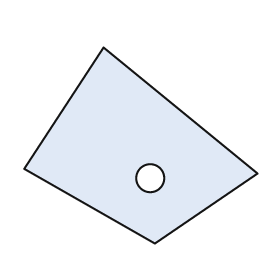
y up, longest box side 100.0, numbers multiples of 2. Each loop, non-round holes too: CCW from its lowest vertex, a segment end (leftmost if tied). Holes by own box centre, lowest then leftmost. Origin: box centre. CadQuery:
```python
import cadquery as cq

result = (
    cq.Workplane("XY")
    .moveTo(6.0, -42.0)
    .lineTo(50.0, -12.0)
    .lineTo(-16.0, 42.0)
    .lineTo(-50.0, -10.0)
    .close()
    .moveTo(4.0, -14.0)
    .circle(6.0)
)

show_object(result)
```